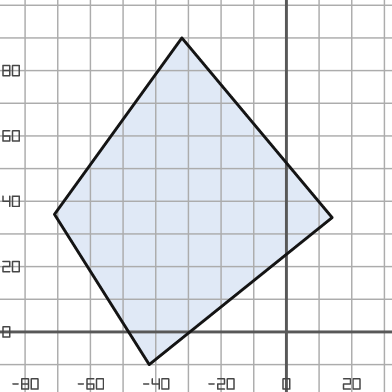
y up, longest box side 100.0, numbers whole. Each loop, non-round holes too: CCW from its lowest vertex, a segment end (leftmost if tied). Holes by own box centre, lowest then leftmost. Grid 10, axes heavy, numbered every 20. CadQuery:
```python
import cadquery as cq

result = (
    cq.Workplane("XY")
    .moveTo(-42.0, -10.0)
    .lineTo(14.0, 35.0)
    .lineTo(-32.0, 90.0)
    .lineTo(-71.0, 36.0)
    .close()
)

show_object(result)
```